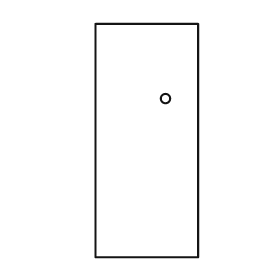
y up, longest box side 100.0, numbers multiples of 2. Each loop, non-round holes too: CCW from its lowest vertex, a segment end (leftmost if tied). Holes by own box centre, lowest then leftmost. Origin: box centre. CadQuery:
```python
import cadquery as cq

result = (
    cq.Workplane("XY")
    .moveTo(-22.0, -50.0)
    .lineTo(22.0, -50.0)
    .lineTo(22.0, 50.0)
    .lineTo(-22.0, 50.0)
    .close()
    .moveTo(8.0, 18.0)
    .circle(2.0)
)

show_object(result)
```